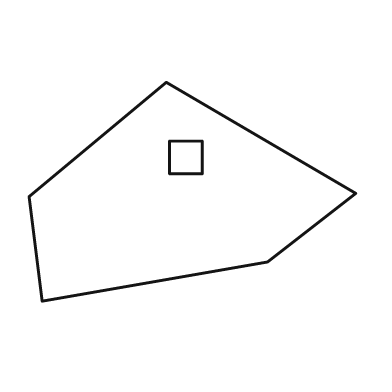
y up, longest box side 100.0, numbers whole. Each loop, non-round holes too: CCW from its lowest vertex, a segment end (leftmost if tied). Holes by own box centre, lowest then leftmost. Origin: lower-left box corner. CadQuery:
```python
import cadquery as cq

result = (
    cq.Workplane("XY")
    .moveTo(4.0, 0.0)
    .lineTo(73.0, 12.0)
    .lineTo(100.0, 33.0)
    .lineTo(42.0, 67.0)
    .lineTo(0.0, 32.0)
    .close()
    .moveTo(43.0, 39.0)
    .lineTo(53.0, 39.0)
    .lineTo(53.0, 49.0)
    .lineTo(43.0, 49.0)
    .close()
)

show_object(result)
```